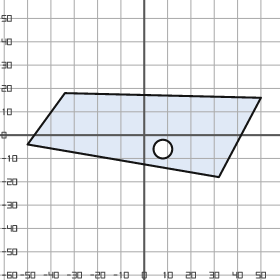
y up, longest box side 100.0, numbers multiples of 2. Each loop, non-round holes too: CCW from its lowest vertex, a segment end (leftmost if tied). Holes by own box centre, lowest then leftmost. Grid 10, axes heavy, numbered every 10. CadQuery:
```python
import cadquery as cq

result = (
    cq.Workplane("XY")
    .moveTo(32.0, -18.0)
    .lineTo(50.0, 16.0)
    .lineTo(-34.0, 18.0)
    .lineTo(-50.0, -4.0)
    .close()
    .moveTo(8.0, -6.0)
    .circle(4.0)
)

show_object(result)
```